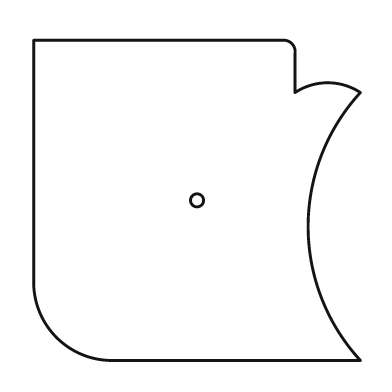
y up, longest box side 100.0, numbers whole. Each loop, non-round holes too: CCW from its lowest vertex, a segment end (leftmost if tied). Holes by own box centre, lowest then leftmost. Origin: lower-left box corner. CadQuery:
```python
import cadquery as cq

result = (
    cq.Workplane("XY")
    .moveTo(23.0, 0.0)
    .lineTo(100.0, 0.0)
    .threePointArc((84.0, 41.0), (100.0, 82.0))
    .threePointArc((90.0, 85.0), (80.0, 82.0))
    .lineTo(80.0, 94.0)
    .threePointArc((79.0, 97.0), (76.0, 98.0))
    .lineTo(0.0, 98.0)
    .lineTo(0.0, 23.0)
    .threePointArc((7.0, 7.0), (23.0, 0.0))
    .close()
    .moveTo(50.0, 49.0)
    .circle(2.0)
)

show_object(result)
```